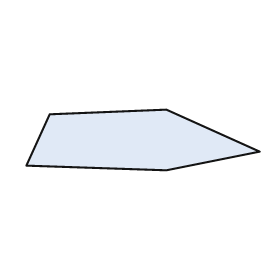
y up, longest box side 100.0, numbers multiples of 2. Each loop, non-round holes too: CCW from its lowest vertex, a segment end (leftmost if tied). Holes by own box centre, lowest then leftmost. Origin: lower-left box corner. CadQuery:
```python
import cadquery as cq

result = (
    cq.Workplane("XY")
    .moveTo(60.0, 0.0)
    .lineTo(100.0, 8.0)
    .lineTo(60.0, 26.0)
    .lineTo(10.0, 24.0)
    .lineTo(0.0, 2.0)
    .close()
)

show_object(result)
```